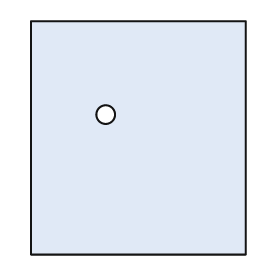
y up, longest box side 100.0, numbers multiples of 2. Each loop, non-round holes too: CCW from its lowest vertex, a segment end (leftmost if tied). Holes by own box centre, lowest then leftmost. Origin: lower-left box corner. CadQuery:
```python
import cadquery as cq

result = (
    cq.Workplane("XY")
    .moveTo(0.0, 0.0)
    .lineTo(92.0, 0.0)
    .lineTo(92.0, 100.0)
    .lineTo(0.0, 100.0)
    .close()
    .moveTo(32.0, 60.0)
    .circle(4.0)
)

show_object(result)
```